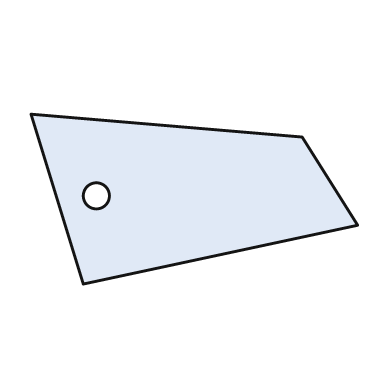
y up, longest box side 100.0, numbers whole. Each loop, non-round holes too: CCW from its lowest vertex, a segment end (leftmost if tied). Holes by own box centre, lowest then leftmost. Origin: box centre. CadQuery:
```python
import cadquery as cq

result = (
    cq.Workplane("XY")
    .moveTo(-34.0, -26.0)
    .lineTo(50.0, -8.0)
    .lineTo(33.0, 19.0)
    .lineTo(-50.0, 26.0)
    .close()
    .moveTo(-30.0, 1.0)
    .circle(4.0)
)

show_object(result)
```